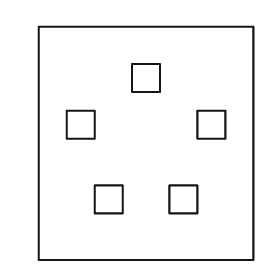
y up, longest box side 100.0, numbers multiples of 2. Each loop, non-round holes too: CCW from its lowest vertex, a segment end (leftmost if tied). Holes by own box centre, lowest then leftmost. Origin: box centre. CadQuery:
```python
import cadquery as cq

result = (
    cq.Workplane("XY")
    .moveTo(-46.0, -50.0)
    .lineTo(46.0, -50.0)
    .lineTo(46.0, 50.0)
    .lineTo(-46.0, 50.0)
    .close()
    .moveTo(-22.0, -30.0)
    .lineTo(-10.0, -30.0)
    .lineTo(-10.0, -18.0)
    .lineTo(-22.0, -18.0)
    .close()
    .moveTo(10.0, -30.0)
    .lineTo(22.0, -30.0)
    .lineTo(22.0, -18.0)
    .lineTo(10.0, -18.0)
    .close()
    .moveTo(-34.0, 2.0)
    .lineTo(-22.0, 2.0)
    .lineTo(-22.0, 14.0)
    .lineTo(-34.0, 14.0)
    .close()
    .moveTo(22.0, 2.0)
    .lineTo(34.0, 2.0)
    .lineTo(34.0, 14.0)
    .lineTo(22.0, 14.0)
    .close()
    .moveTo(-6.0, 22.0)
    .lineTo(6.0, 22.0)
    .lineTo(6.0, 34.0)
    .lineTo(-6.0, 34.0)
    .close()
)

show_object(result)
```